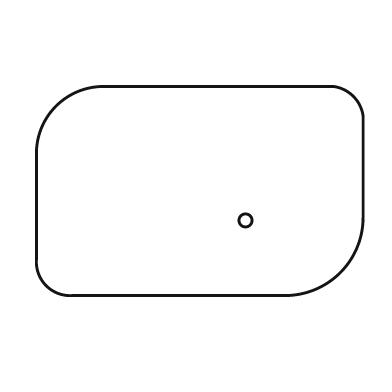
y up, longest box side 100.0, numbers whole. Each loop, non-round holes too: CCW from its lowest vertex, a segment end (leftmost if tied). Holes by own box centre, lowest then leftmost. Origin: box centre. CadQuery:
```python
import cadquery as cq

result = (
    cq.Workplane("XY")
    .moveTo(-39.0, -32.0)
    .lineTo(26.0, -32.0)
    .threePointArc((43.0, -25.0), (50.0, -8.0))
    .lineTo(50.0, 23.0)
    .threePointArc((47.0, 29.0), (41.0, 32.0))
    .lineTo(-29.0, 32.0)
    .threePointArc((-44.0, 26.0), (-50.0, 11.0))
    .lineTo(-50.0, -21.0)
    .threePointArc((-47.0, -29.0), (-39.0, -32.0))
    .close()
    .moveTo(14.0, -9.0)
    .circle(2.0)
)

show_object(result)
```